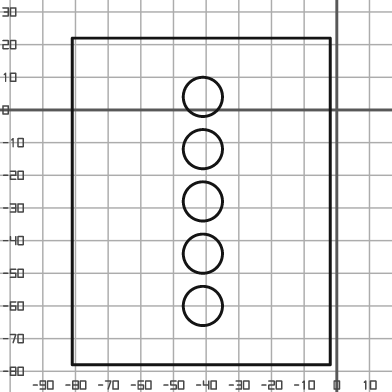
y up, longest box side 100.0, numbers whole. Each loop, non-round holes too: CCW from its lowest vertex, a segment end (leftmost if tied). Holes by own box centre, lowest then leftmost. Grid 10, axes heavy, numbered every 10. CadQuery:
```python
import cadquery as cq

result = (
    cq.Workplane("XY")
    .moveTo(-81.0, -78.0)
    .lineTo(-2.0, -78.0)
    .lineTo(-2.0, 22.0)
    .lineTo(-81.0, 22.0)
    .close()
    .moveTo(-41.0, -60.0)
    .circle(6.0)
    .moveTo(-41.0, -44.0)
    .circle(6.0)
    .moveTo(-41.0, -28.0)
    .circle(6.0)
    .moveTo(-41.0, -12.0)
    .circle(6.0)
    .moveTo(-41.0, 4.0)
    .circle(6.0)
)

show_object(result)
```